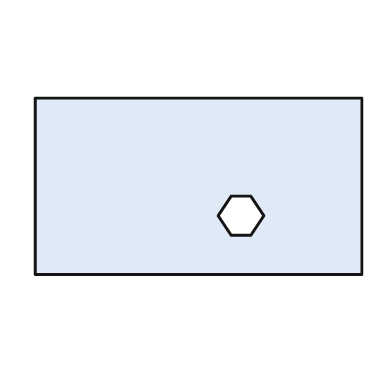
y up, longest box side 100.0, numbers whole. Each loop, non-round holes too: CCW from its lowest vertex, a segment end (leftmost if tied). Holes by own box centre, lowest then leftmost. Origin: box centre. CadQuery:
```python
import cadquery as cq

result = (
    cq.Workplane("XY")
    .moveTo(-50.0, -27.0)
    .lineTo(50.0, -27.0)
    .lineTo(50.0, 27.0)
    .lineTo(-50.0, 27.0)
    .close()
    .moveTo(10.0, -15.0)
    .lineTo(16.0, -15.0)
    .lineTo(20.0, -9.0)
    .lineTo(16.0, -3.0)
    .lineTo(10.0, -3.0)
    .lineTo(6.0, -9.0)
    .close()
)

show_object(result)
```